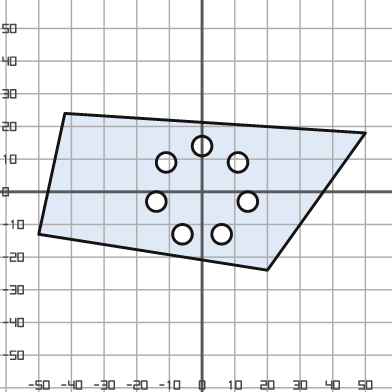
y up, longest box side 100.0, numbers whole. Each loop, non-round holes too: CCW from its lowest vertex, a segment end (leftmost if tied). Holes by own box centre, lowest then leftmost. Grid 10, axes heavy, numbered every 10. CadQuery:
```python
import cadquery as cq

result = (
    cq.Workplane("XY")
    .moveTo(20.0, -24.0)
    .lineTo(50.0, 18.0)
    .lineTo(-42.0, 24.0)
    .lineTo(-50.0, -13.0)
    .close()
    .moveTo(-6.0, -13.0)
    .circle(3.0)
    .moveTo(6.0, -13.0)
    .circle(3.0)
    .moveTo(-14.0, -3.0)
    .circle(3.0)
    .moveTo(14.0, -3.0)
    .circle(3.0)
    .moveTo(-11.0, 9.0)
    .circle(3.0)
    .moveTo(11.0, 9.0)
    .circle(3.0)
    .moveTo(0.0, 14.0)
    .circle(3.0)
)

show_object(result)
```